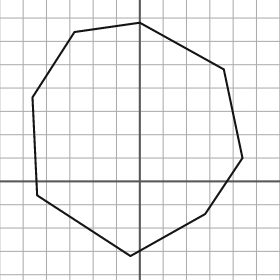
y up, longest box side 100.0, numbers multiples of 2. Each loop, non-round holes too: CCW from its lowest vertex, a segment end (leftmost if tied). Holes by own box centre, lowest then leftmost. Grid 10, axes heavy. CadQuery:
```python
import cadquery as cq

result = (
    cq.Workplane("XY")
    .moveTo(-4.0, -32.0)
    .lineTo(28.0, -14.0)
    .lineTo(44.0, 10.0)
    .lineTo(36.0, 48.0)
    .lineTo(0.0, 68.0)
    .lineTo(-28.0, 64.0)
    .lineTo(-46.0, 36.0)
    .lineTo(-44.0, -6.0)
    .close()
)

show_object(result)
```